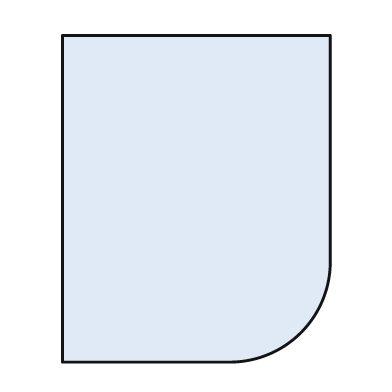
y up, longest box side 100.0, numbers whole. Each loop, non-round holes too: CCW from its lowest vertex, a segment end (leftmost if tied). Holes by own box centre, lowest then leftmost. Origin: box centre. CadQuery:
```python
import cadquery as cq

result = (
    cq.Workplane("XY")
    .moveTo(-41.0, -50.0)
    .lineTo(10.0, -50.0)
    .threePointArc((32.0, -41.0), (41.0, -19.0))
    .lineTo(41.0, 50.0)
    .lineTo(-41.0, 50.0)
    .close()
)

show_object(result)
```